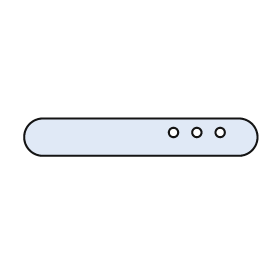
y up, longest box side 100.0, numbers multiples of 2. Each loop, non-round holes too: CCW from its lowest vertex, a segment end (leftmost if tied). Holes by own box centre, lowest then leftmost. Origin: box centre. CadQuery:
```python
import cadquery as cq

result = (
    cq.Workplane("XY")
    .moveTo(-42.0, -8.0)
    .lineTo(42.0, -8.0)
    .threePointArc((50.0, 0.0), (42.0, 8.0))
    .lineTo(-42.0, 8.0)
    .threePointArc((-50.0, 0.0), (-42.0, -8.0))
    .close()
    .moveTo(14.0, 2.0)
    .circle(2.0)
    .moveTo(24.0, 2.0)
    .circle(2.0)
    .moveTo(34.0, 2.0)
    .circle(2.0)
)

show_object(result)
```